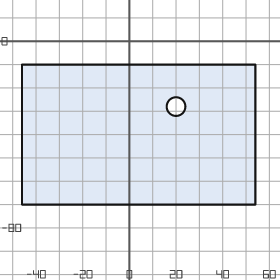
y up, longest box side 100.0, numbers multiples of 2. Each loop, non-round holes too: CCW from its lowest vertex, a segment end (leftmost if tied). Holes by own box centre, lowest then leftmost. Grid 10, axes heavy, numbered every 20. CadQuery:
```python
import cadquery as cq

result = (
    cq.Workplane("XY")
    .moveTo(-46.0, -70.0)
    .lineTo(54.0, -70.0)
    .lineTo(54.0, -10.0)
    .lineTo(-46.0, -10.0)
    .close()
    .moveTo(20.0, -28.0)
    .circle(4.0)
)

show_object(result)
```